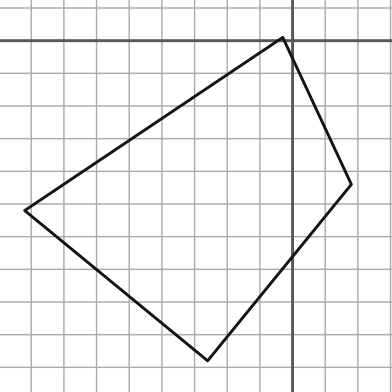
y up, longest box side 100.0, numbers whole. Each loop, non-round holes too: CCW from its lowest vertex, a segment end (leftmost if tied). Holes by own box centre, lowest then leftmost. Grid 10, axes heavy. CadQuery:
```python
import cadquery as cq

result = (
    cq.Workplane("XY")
    .moveTo(-26.0, -98.0)
    .lineTo(18.0, -44.0)
    .lineTo(-3.0, 1.0)
    .lineTo(-82.0, -52.0)
    .close()
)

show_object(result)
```